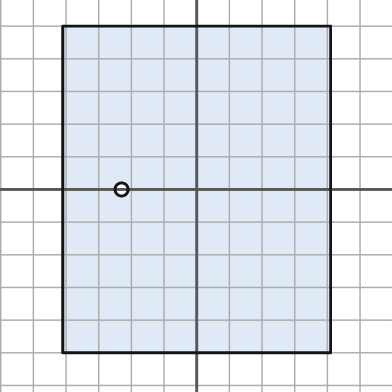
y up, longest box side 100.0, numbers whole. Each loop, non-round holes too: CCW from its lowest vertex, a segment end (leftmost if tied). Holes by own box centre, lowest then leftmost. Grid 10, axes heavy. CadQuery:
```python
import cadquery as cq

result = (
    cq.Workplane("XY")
    .moveTo(-41.0, -50.0)
    .lineTo(41.0, -50.0)
    .lineTo(41.0, 50.0)
    .lineTo(-41.0, 50.0)
    .close()
    .moveTo(-23.0, 0.0)
    .circle(2.0)
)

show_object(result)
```